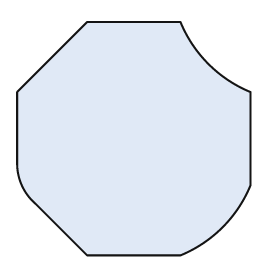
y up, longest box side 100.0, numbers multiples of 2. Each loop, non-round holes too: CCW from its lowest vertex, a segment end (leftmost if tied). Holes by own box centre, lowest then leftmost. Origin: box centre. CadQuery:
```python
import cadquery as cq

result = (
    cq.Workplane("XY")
    .moveTo(-20.0, -50.0)
    .lineTo(20.0, -50.0)
    .threePointArc((38.0, -38.0), (50.0, -20.0))
    .lineTo(50.0, 20.0)
    .threePointArc((32.0, 32.0), (20.0, 50.0))
    .lineTo(-20.0, 50.0)
    .lineTo(-50.0, 20.0)
    .lineTo(-50.0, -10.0)
    .threePointArc((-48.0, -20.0), (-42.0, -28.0))
    .close()
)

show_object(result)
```